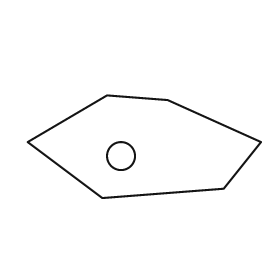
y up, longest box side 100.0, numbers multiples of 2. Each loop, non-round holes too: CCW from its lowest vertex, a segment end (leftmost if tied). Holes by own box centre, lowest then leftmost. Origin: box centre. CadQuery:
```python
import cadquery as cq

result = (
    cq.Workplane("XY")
    .moveTo(-18.0, -22.0)
    .lineTo(34.0, -18.0)
    .lineTo(50.0, 2.0)
    .lineTo(10.0, 20.0)
    .lineTo(-16.0, 22.0)
    .lineTo(-50.0, 2.0)
    .close()
    .moveTo(-10.0, -4.0)
    .circle(6.0)
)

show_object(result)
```